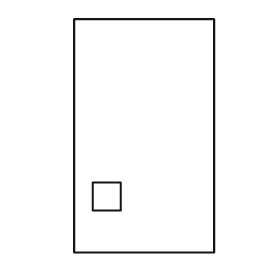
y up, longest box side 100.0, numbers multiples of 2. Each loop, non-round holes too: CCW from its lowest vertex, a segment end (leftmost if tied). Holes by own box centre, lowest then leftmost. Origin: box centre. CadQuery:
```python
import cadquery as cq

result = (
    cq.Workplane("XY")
    .moveTo(-30.0, -50.0)
    .lineTo(30.0, -50.0)
    .lineTo(30.0, 50.0)
    .lineTo(-30.0, 50.0)
    .close()
    .moveTo(-22.0, -32.0)
    .lineTo(-10.0, -32.0)
    .lineTo(-10.0, -20.0)
    .lineTo(-22.0, -20.0)
    .close()
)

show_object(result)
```